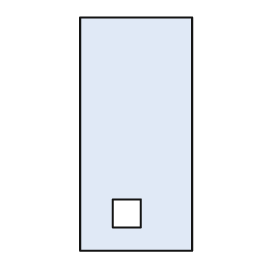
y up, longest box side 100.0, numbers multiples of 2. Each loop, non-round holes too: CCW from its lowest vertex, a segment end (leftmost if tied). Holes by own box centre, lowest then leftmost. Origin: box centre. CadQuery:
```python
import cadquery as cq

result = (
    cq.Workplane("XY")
    .moveTo(-24.0, -50.0)
    .lineTo(24.0, -50.0)
    .lineTo(24.0, 50.0)
    .lineTo(-24.0, 50.0)
    .close()
    .moveTo(-10.0, -40.0)
    .lineTo(2.0, -40.0)
    .lineTo(2.0, -28.0)
    .lineTo(-10.0, -28.0)
    .close()
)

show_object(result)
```